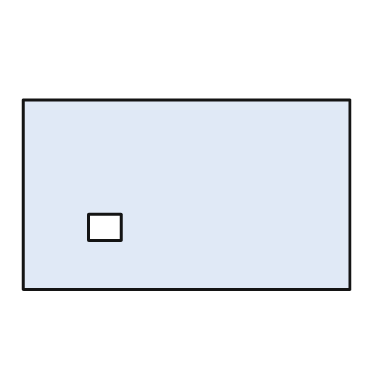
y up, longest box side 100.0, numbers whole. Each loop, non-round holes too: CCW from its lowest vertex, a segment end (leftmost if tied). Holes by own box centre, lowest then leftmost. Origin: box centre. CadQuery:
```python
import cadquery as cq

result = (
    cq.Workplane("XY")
    .moveTo(-50.0, -29.0)
    .lineTo(50.0, -29.0)
    .lineTo(50.0, 29.0)
    .lineTo(-50.0, 29.0)
    .close()
    .moveTo(-30.0, -14.0)
    .lineTo(-20.0, -14.0)
    .lineTo(-20.0, -6.0)
    .lineTo(-30.0, -6.0)
    .close()
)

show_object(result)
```